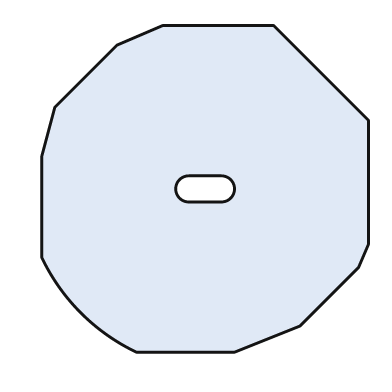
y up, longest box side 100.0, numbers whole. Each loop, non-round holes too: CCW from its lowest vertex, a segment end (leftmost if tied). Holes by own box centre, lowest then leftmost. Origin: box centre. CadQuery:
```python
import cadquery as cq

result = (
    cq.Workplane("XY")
    .moveTo(-21.0, -50.0)
    .lineTo(9.0, -50.0)
    .lineTo(29.0, -42.0)
    .lineTo(47.0, -24.0)
    .lineTo(50.0, -17.0)
    .lineTo(50.0, 21.0)
    .lineTo(21.0, 50.0)
    .lineTo(-13.0, 50.0)
    .lineTo(-27.0, 44.0)
    .lineTo(-46.0, 25.0)
    .lineTo(-50.0, 10.0)
    .lineTo(-50.0, -21.0)
    .threePointArc((-38.0, -38.0), (-21.0, -50.0))
    .close()
    .moveTo(-5.0, -4.0)
    .lineTo(5.0, -4.0)
    .threePointArc((9.0, 0.0), (5.0, 4.0))
    .lineTo(-5.0, 4.0)
    .threePointArc((-9.0, 0.0), (-5.0, -4.0))
    .close()
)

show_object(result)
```